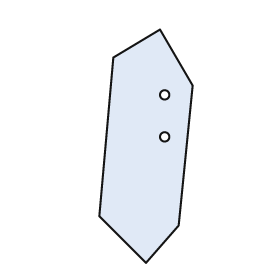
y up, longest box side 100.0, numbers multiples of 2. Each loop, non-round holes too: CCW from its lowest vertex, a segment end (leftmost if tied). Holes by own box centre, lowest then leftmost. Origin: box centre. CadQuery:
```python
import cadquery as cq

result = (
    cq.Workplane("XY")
    .moveTo(0.0, -50.0)
    .lineTo(14.0, -34.0)
    .lineTo(20.0, 26.0)
    .lineTo(6.0, 50.0)
    .lineTo(-14.0, 38.0)
    .lineTo(-20.0, -30.0)
    .close()
    .moveTo(8.0, 4.0)
    .circle(2.0)
    .moveTo(8.0, 22.0)
    .circle(2.0)
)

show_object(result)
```